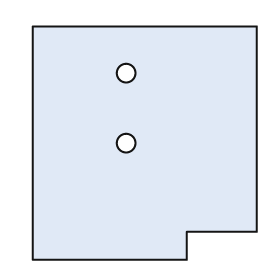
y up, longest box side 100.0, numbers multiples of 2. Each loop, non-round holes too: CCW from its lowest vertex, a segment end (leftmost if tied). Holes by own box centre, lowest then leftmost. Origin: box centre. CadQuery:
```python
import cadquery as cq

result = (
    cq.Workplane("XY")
    .moveTo(-48.0, -50.0)
    .lineTo(18.0, -50.0)
    .lineTo(18.0, -38.0)
    .lineTo(48.0, -38.0)
    .lineTo(48.0, 50.0)
    .lineTo(-48.0, 50.0)
    .close()
    .moveTo(-8.0, 0.0)
    .circle(4.0)
    .moveTo(-8.0, 30.0)
    .circle(4.0)
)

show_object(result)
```